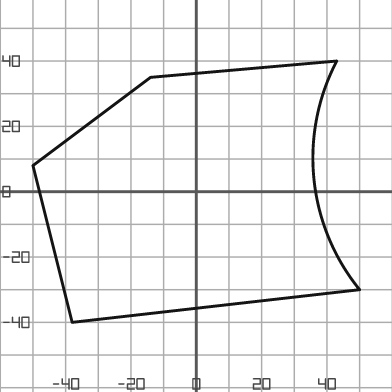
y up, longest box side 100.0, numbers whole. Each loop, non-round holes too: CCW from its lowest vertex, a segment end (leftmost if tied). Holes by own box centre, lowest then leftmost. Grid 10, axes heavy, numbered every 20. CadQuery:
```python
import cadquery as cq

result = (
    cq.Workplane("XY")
    .moveTo(-38.0, -40.0)
    .lineTo(50.0, -30.0)
    .threePointArc((36.0, 4.0), (43.0, 40.0))
    .lineTo(-14.0, 35.0)
    .lineTo(-50.0, 8.0)
    .close()
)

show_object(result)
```